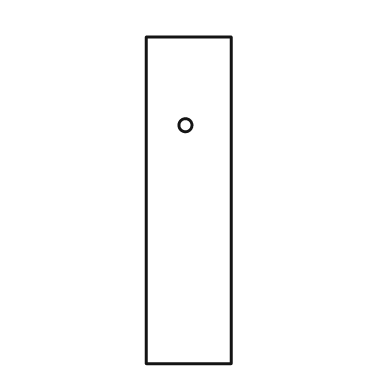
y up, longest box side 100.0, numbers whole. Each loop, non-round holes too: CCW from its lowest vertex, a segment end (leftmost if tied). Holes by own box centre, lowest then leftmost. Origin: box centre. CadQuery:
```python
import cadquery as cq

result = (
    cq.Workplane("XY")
    .moveTo(-13.0, -50.0)
    .lineTo(13.0, -50.0)
    .lineTo(13.0, 50.0)
    .lineTo(-13.0, 50.0)
    .close()
    .moveTo(-1.0, 23.0)
    .circle(2.0)
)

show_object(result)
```